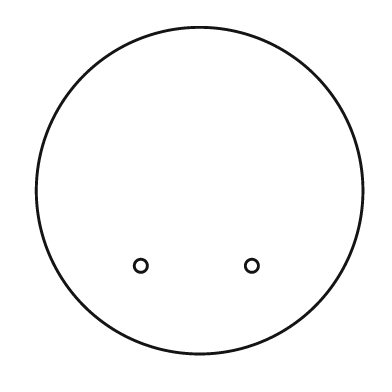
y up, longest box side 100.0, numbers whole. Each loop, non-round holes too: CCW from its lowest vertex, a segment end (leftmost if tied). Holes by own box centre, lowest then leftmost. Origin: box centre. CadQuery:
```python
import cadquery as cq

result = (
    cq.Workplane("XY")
    .moveTo(0.0, 0.0)
    .circle(50.0)
    .moveTo(-18.0, -23.0)
    .circle(2.0)
    .moveTo(16.0, -23.0)
    .circle(2.0)
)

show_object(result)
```